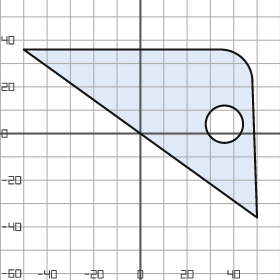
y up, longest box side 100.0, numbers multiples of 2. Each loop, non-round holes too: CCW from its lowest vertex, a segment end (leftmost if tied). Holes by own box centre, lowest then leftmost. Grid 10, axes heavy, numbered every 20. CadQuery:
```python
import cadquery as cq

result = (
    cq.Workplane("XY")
    .moveTo(50.0, -36.0)
    .lineTo(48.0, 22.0)
    .threePointArc((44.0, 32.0), (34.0, 36.0))
    .lineTo(-50.0, 36.0)
    .close()
    .moveTo(36.0, 4.0)
    .circle(8.0)
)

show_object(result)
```